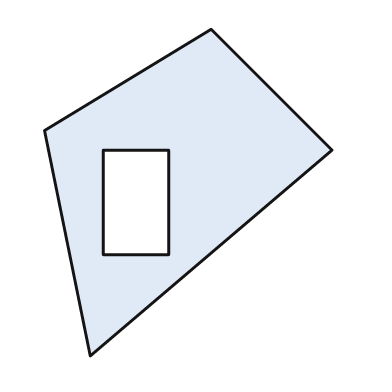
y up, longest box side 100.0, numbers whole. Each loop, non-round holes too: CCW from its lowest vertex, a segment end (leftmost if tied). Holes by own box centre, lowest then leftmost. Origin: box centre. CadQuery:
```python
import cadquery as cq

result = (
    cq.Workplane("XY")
    .moveTo(-30.0, -50.0)
    .lineTo(44.0, 13.0)
    .lineTo(7.0, 50.0)
    .lineTo(-44.0, 19.0)
    .close()
    .moveTo(-26.0, -19.0)
    .lineTo(-6.0, -19.0)
    .lineTo(-6.0, 13.0)
    .lineTo(-26.0, 13.0)
    .close()
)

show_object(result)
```